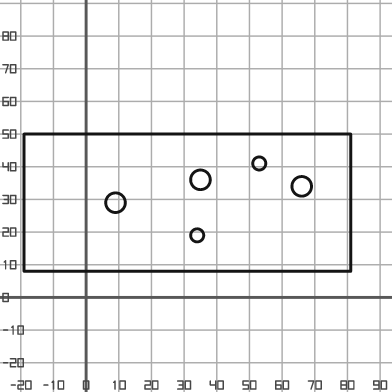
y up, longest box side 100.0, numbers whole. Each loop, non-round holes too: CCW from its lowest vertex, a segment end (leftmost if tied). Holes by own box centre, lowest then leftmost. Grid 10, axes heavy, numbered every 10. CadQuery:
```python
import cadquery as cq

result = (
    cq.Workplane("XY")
    .moveTo(-19.0, 8.0)
    .lineTo(81.0, 8.0)
    .lineTo(81.0, 50.0)
    .lineTo(-19.0, 50.0)
    .close()
    .moveTo(34.0, 19.0)
    .circle(2.0)
    .moveTo(9.0, 29.0)
    .circle(3.0)
    .moveTo(66.0, 34.0)
    .circle(3.0)
    .moveTo(35.0, 36.0)
    .circle(3.0)
    .moveTo(53.0, 41.0)
    .circle(2.0)
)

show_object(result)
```